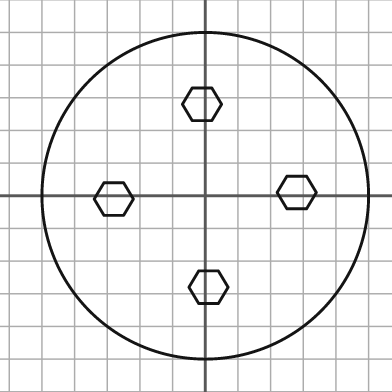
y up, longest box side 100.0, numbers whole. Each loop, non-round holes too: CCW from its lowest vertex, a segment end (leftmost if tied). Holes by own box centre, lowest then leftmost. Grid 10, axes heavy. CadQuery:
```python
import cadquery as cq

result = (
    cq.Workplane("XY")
    .moveTo(0.0, 0.0)
    .circle(50.0)
    .moveTo(-2.0, -33.0)
    .lineTo(4.0, -33.0)
    .lineTo(7.0, -28.0)
    .lineTo(4.0, -23.0)
    .lineTo(-2.0, -23.0)
    .lineTo(-5.0, -28.0)
    .close()
    .moveTo(-31.0, -6.0)
    .lineTo(-25.0, -6.0)
    .lineTo(-22.0, -1.0)
    .lineTo(-25.0, 4.0)
    .lineTo(-31.0, 4.0)
    .lineTo(-34.0, -1.0)
    .close()
    .moveTo(25.0, -4.0)
    .lineTo(31.0, -4.0)
    .lineTo(34.0, 1.0)
    .lineTo(31.0, 6.0)
    .lineTo(25.0, 6.0)
    .lineTo(22.0, 1.0)
    .close()
    .moveTo(-4.0, 23.0)
    .lineTo(2.0, 23.0)
    .lineTo(5.0, 28.0)
    .lineTo(2.0, 33.0)
    .lineTo(-4.0, 33.0)
    .lineTo(-7.0, 28.0)
    .close()
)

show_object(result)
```